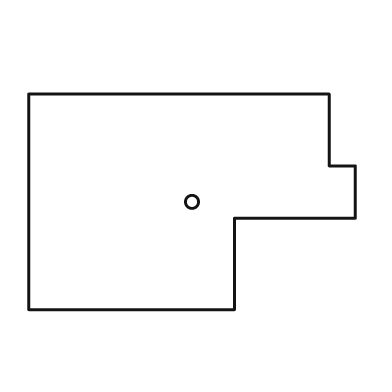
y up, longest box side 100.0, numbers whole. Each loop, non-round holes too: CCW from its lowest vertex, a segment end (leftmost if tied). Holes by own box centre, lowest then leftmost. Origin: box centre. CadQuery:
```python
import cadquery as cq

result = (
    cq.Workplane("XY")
    .moveTo(-50.0, -33.0)
    .lineTo(13.0, -33.0)
    .lineTo(13.0, -5.0)
    .lineTo(50.0, -5.0)
    .lineTo(50.0, 11.0)
    .lineTo(42.0, 11.0)
    .lineTo(42.0, 33.0)
    .lineTo(-50.0, 33.0)
    .close()
    .moveTo(0.0, 0.0)
    .circle(2.0)
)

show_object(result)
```